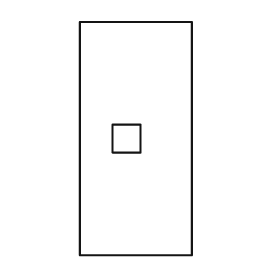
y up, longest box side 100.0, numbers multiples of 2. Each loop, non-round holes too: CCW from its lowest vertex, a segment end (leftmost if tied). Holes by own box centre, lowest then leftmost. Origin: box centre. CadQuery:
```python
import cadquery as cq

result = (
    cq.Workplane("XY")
    .moveTo(-24.0, -50.0)
    .lineTo(24.0, -50.0)
    .lineTo(24.0, 50.0)
    .lineTo(-24.0, 50.0)
    .close()
    .moveTo(-10.0, -6.0)
    .lineTo(2.0, -6.0)
    .lineTo(2.0, 6.0)
    .lineTo(-10.0, 6.0)
    .close()
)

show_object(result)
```